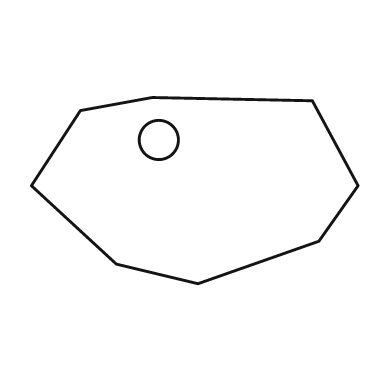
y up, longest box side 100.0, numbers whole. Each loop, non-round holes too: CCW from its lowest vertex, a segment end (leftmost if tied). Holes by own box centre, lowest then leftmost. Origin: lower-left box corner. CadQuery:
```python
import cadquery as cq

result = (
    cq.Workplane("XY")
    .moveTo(51.0, 0.0)
    .lineTo(88.0, 13.0)
    .lineTo(100.0, 30.0)
    .lineTo(86.0, 56.0)
    .lineTo(37.0, 57.0)
    .lineTo(15.0, 53.0)
    .lineTo(0.0, 30.0)
    .lineTo(26.0, 6.0)
    .close()
    .moveTo(39.0, 44.0)
    .circle(6.0)
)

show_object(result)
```